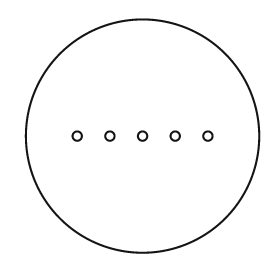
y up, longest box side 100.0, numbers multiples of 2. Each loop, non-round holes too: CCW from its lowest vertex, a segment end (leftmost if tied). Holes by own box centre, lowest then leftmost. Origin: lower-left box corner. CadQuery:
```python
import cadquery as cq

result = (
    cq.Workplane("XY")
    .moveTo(50.0, 50.0)
    .circle(50.0)
    .moveTo(22.0, 50.0)
    .circle(2.0)
    .moveTo(36.0, 50.0)
    .circle(2.0)
    .moveTo(50.0, 50.0)
    .circle(2.0)
    .moveTo(64.0, 50.0)
    .circle(2.0)
    .moveTo(78.0, 50.0)
    .circle(2.0)
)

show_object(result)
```